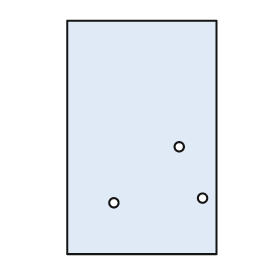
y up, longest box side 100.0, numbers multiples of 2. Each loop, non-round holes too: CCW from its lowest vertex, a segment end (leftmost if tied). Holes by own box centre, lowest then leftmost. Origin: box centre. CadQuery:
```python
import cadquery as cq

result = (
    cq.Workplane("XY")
    .moveTo(-32.0, -50.0)
    .lineTo(32.0, -50.0)
    .lineTo(32.0, 50.0)
    .lineTo(-32.0, 50.0)
    .close()
    .moveTo(-12.0, -28.0)
    .circle(2.0)
    .moveTo(26.0, -26.0)
    .circle(2.0)
    .moveTo(16.0, -4.0)
    .circle(2.0)
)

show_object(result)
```